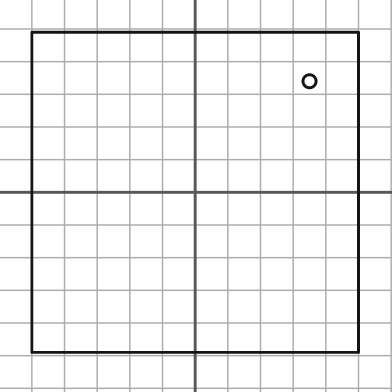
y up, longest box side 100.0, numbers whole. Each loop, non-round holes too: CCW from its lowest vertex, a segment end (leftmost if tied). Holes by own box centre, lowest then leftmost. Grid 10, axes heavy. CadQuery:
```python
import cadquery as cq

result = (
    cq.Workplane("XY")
    .moveTo(-50.0, -49.0)
    .lineTo(50.0, -49.0)
    .lineTo(50.0, 49.0)
    .lineTo(-50.0, 49.0)
    .close()
    .moveTo(35.0, 34.0)
    .circle(2.0)
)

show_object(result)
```